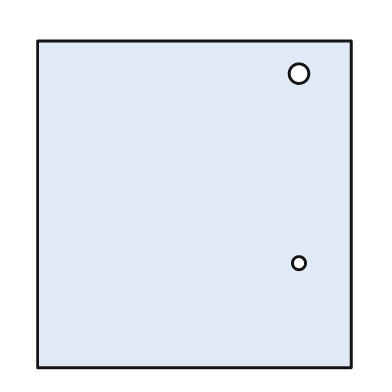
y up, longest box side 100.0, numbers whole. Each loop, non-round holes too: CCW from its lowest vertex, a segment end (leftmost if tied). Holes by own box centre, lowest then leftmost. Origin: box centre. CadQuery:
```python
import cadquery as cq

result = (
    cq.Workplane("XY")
    .moveTo(-48.0, -50.0)
    .lineTo(48.0, -50.0)
    .lineTo(48.0, 50.0)
    .lineTo(-48.0, 50.0)
    .close()
    .moveTo(32.0, -18.0)
    .circle(2.0)
    .moveTo(32.0, 40.0)
    .circle(3.0)
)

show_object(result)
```